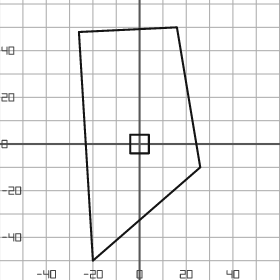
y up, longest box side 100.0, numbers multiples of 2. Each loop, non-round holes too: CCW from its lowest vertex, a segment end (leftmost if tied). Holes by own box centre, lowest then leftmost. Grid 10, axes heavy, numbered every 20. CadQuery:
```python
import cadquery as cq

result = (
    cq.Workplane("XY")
    .moveTo(-20.0, -50.0)
    .lineTo(26.0, -10.0)
    .lineTo(16.0, 50.0)
    .lineTo(-26.0, 48.0)
    .close()
    .moveTo(-4.0, -4.0)
    .lineTo(4.0, -4.0)
    .lineTo(4.0, 4.0)
    .lineTo(-4.0, 4.0)
    .close()
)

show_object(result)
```